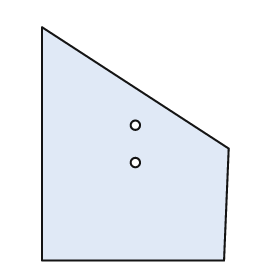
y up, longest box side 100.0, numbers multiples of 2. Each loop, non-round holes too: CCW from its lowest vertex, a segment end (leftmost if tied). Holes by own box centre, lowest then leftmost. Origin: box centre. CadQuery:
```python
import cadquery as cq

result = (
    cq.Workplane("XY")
    .moveTo(-40.0, -50.0)
    .lineTo(38.0, -50.0)
    .lineTo(40.0, -2.0)
    .lineTo(-40.0, 50.0)
    .close()
    .moveTo(0.0, -8.0)
    .circle(2.0)
    .moveTo(0.0, 8.0)
    .circle(2.0)
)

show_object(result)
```